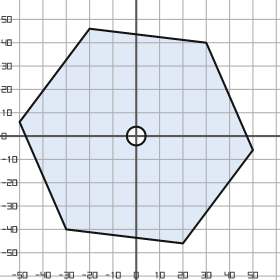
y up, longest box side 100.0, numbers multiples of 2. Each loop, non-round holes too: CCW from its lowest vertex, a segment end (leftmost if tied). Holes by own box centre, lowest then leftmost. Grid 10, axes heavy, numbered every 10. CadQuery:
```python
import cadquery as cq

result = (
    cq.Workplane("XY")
    .moveTo(20.0, -46.0)
    .lineTo(50.0, -6.0)
    .lineTo(30.0, 40.0)
    .lineTo(-20.0, 46.0)
    .lineTo(-50.0, 6.0)
    .lineTo(-30.0, -40.0)
    .close()
    .moveTo(0.0, 0.0)
    .circle(4.0)
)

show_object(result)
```